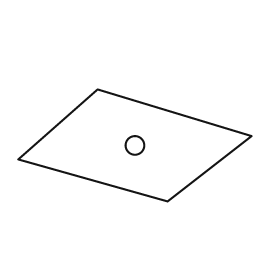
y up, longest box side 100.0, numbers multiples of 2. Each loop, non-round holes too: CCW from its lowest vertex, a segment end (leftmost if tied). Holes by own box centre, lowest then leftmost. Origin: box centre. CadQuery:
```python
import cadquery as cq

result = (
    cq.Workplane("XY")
    .moveTo(14.0, -24.0)
    .lineTo(50.0, 4.0)
    .lineTo(-16.0, 24.0)
    .lineTo(-50.0, -6.0)
    .close()
    .moveTo(0.0, 0.0)
    .circle(4.0)
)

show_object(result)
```